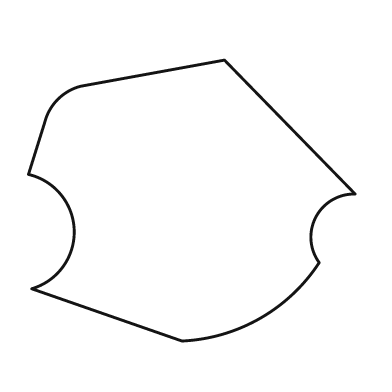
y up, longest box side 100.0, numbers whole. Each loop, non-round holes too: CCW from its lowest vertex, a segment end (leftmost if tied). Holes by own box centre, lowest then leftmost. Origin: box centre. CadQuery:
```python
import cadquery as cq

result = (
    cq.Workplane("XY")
    .moveTo(-3.0, -43.0)
    .threePointArc((21.0, -36.0), (39.0, -19.0))
    .threePointArc((38.0, -5.0), (50.0, 2.0))
    .lineTo(10.0, 43.0)
    .lineTo(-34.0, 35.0)
    .threePointArc((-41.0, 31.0), (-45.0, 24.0))
    .lineTo(-50.0, 8.0)
    .threePointArc((-36.0, -9.0), (-49.0, -27.0))
    .close()
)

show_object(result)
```